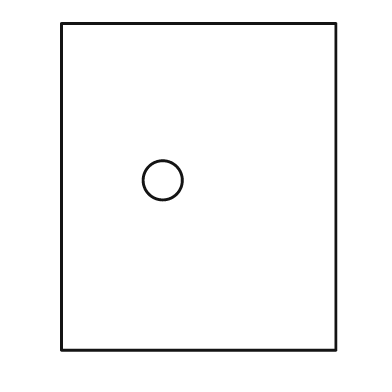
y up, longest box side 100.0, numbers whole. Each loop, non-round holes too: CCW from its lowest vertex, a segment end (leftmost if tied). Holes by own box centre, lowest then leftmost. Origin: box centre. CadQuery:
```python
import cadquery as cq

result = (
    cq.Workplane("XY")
    .moveTo(-42.0, -50.0)
    .lineTo(42.0, -50.0)
    .lineTo(42.0, 50.0)
    .lineTo(-42.0, 50.0)
    .close()
    .moveTo(-11.0, 2.0)
    .circle(6.0)
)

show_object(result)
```